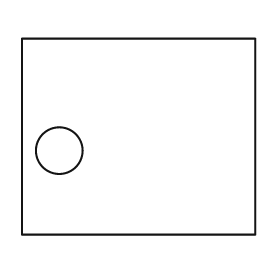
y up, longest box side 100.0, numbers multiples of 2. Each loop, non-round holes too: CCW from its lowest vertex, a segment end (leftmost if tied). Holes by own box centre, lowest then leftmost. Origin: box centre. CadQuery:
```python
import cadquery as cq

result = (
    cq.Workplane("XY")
    .moveTo(-50.0, -42.0)
    .lineTo(50.0, -42.0)
    .lineTo(50.0, 42.0)
    .lineTo(-50.0, 42.0)
    .close()
    .moveTo(-34.0, -6.0)
    .circle(10.0)
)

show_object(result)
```